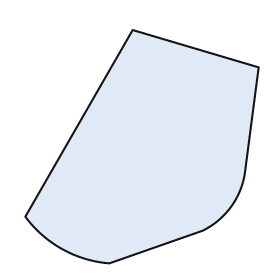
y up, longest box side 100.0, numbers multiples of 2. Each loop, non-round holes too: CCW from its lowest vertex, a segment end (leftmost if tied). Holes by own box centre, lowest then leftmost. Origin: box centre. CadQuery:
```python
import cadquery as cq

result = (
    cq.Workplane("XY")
    .moveTo(-14.0, -50.0)
    .lineTo(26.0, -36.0)
    .threePointArc((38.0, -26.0), (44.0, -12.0))
    .lineTo(50.0, 34.0)
    .lineTo(-4.0, 50.0)
    .lineTo(-50.0, -30.0)
    .threePointArc((-34.0, -44.0), (-14.0, -50.0))
    .close()
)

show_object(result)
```